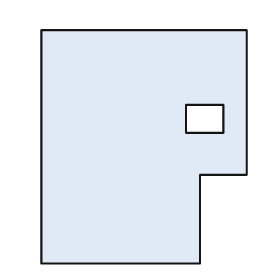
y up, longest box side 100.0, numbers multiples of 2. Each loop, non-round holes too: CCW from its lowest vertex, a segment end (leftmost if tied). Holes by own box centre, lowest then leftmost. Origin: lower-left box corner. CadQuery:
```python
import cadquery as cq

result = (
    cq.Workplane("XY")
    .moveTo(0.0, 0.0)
    .lineTo(68.0, 0.0)
    .lineTo(68.0, 38.0)
    .lineTo(88.0, 38.0)
    .lineTo(88.0, 100.0)
    .lineTo(0.0, 100.0)
    .close()
    .moveTo(62.0, 56.0)
    .lineTo(78.0, 56.0)
    .lineTo(78.0, 68.0)
    .lineTo(62.0, 68.0)
    .close()
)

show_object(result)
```